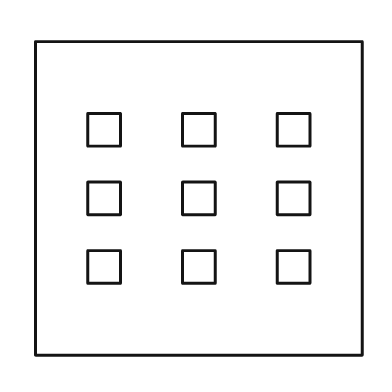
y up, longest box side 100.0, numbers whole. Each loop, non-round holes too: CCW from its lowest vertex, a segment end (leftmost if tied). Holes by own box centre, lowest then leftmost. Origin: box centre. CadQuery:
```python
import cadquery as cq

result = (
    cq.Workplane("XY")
    .moveTo(-50.0, -48.0)
    .lineTo(50.0, -48.0)
    .lineTo(50.0, 48.0)
    .lineTo(-50.0, 48.0)
    .close()
    .moveTo(-34.0, -26.0)
    .lineTo(-24.0, -26.0)
    .lineTo(-24.0, -16.0)
    .lineTo(-34.0, -16.0)
    .close()
    .moveTo(-5.0, -26.0)
    .lineTo(5.0, -26.0)
    .lineTo(5.0, -16.0)
    .lineTo(-5.0, -16.0)
    .close()
    .moveTo(24.0, -26.0)
    .lineTo(34.0, -26.0)
    .lineTo(34.0, -16.0)
    .lineTo(24.0, -16.0)
    .close()
    .moveTo(-34.0, -5.0)
    .lineTo(-24.0, -5.0)
    .lineTo(-24.0, 5.0)
    .lineTo(-34.0, 5.0)
    .close()
    .moveTo(-5.0, -5.0)
    .lineTo(5.0, -5.0)
    .lineTo(5.0, 5.0)
    .lineTo(-5.0, 5.0)
    .close()
    .moveTo(24.0, -5.0)
    .lineTo(34.0, -5.0)
    .lineTo(34.0, 5.0)
    .lineTo(24.0, 5.0)
    .close()
    .moveTo(-34.0, 16.0)
    .lineTo(-24.0, 16.0)
    .lineTo(-24.0, 26.0)
    .lineTo(-34.0, 26.0)
    .close()
    .moveTo(-5.0, 16.0)
    .lineTo(5.0, 16.0)
    .lineTo(5.0, 26.0)
    .lineTo(-5.0, 26.0)
    .close()
    .moveTo(24.0, 16.0)
    .lineTo(34.0, 16.0)
    .lineTo(34.0, 26.0)
    .lineTo(24.0, 26.0)
    .close()
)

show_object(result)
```